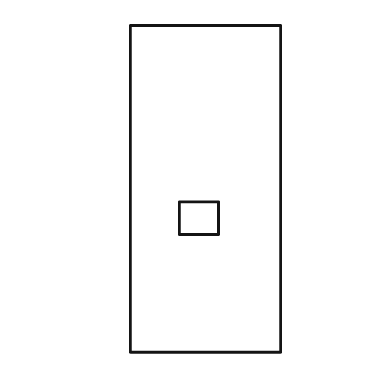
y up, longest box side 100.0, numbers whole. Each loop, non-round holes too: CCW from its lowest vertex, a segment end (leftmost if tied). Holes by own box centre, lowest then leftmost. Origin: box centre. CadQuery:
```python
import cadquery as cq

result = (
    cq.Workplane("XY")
    .moveTo(-23.0, -50.0)
    .lineTo(23.0, -50.0)
    .lineTo(23.0, 50.0)
    .lineTo(-23.0, 50.0)
    .close()
    .moveTo(-8.0, -14.0)
    .lineTo(4.0, -14.0)
    .lineTo(4.0, -4.0)
    .lineTo(-8.0, -4.0)
    .close()
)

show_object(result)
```